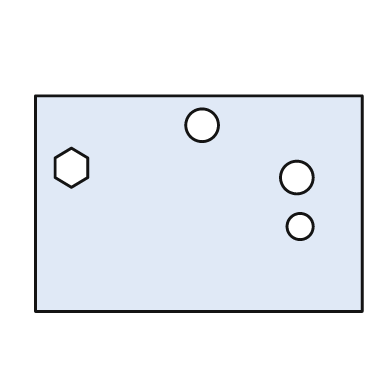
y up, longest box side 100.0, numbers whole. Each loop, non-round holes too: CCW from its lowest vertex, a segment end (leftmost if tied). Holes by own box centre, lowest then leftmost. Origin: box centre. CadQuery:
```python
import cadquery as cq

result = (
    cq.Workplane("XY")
    .moveTo(-50.0, -33.0)
    .lineTo(50.0, -33.0)
    .lineTo(50.0, 33.0)
    .lineTo(-50.0, 33.0)
    .close()
    .moveTo(31.0, -7.0)
    .circle(4.0)
    .moveTo(30.0, 8.0)
    .circle(5.0)
    .moveTo(-39.0, 5.0)
    .lineTo(-34.0, 8.0)
    .lineTo(-34.0, 14.0)
    .lineTo(-39.0, 17.0)
    .lineTo(-44.0, 14.0)
    .lineTo(-44.0, 8.0)
    .close()
    .moveTo(1.0, 24.0)
    .circle(5.0)
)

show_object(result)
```